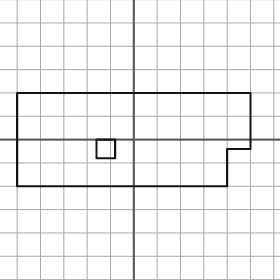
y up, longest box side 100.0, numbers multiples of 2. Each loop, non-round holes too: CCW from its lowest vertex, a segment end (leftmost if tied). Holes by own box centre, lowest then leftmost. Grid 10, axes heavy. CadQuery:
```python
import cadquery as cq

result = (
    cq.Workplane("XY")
    .moveTo(-50.0, -20.0)
    .lineTo(40.0, -20.0)
    .lineTo(40.0, -4.0)
    .lineTo(50.0, -4.0)
    .lineTo(50.0, 20.0)
    .lineTo(-50.0, 20.0)
    .close()
    .moveTo(-16.0, -8.0)
    .lineTo(-8.0, -8.0)
    .lineTo(-8.0, 0.0)
    .lineTo(-16.0, 0.0)
    .close()
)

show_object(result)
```